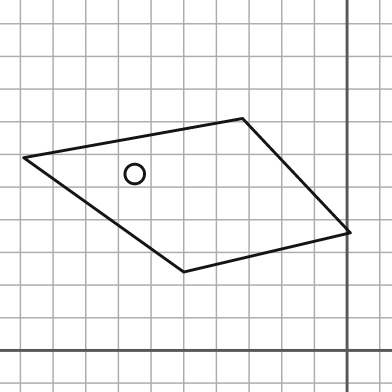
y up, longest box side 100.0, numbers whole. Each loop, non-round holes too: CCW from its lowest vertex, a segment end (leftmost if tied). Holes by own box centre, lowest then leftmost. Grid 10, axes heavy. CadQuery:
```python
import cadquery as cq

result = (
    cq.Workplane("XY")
    .moveTo(-50.0, 24.0)
    .lineTo(1.0, 36.0)
    .lineTo(-32.0, 71.0)
    .lineTo(-99.0, 59.0)
    .close()
    .moveTo(-65.0, 54.0)
    .circle(3.0)
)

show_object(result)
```